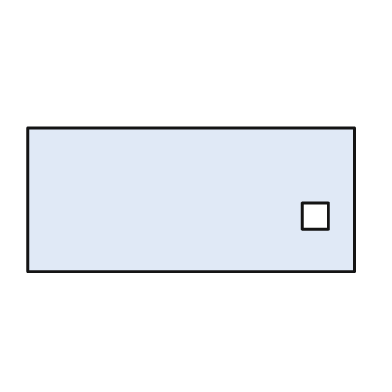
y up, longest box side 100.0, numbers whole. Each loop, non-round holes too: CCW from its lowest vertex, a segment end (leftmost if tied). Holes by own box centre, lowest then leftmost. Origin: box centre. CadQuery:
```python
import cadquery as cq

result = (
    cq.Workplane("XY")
    .moveTo(-50.0, -22.0)
    .lineTo(50.0, -22.0)
    .lineTo(50.0, 22.0)
    .lineTo(-50.0, 22.0)
    .close()
    .moveTo(34.0, -9.0)
    .lineTo(42.0, -9.0)
    .lineTo(42.0, -1.0)
    .lineTo(34.0, -1.0)
    .close()
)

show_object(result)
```